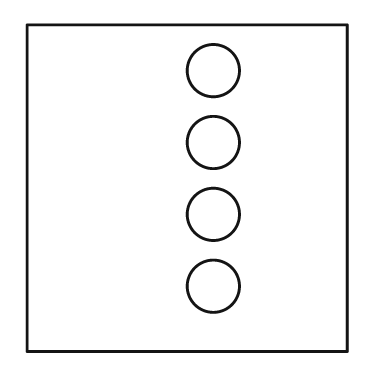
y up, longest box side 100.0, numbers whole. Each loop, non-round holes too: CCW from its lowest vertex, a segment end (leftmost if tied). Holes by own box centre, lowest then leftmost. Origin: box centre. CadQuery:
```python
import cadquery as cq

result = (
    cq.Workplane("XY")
    .moveTo(-49.0, -50.0)
    .lineTo(49.0, -50.0)
    .lineTo(49.0, 50.0)
    .lineTo(-49.0, 50.0)
    .close()
    .moveTo(8.0, -30.0)
    .circle(8.0)
    .moveTo(8.0, -8.0)
    .circle(8.0)
    .moveTo(8.0, 14.0)
    .circle(8.0)
    .moveTo(8.0, 36.0)
    .circle(8.0)
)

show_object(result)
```